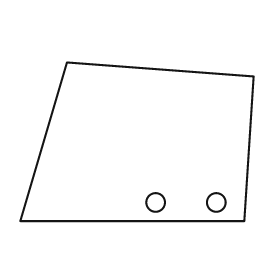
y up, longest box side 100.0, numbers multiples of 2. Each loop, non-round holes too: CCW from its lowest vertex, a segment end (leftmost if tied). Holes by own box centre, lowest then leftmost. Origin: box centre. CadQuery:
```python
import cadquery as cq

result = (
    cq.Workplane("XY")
    .moveTo(-50.0, -34.0)
    .lineTo(46.0, -34.0)
    .lineTo(50.0, 28.0)
    .lineTo(-30.0, 34.0)
    .close()
    .moveTo(8.0, -26.0)
    .circle(4.0)
    .moveTo(34.0, -26.0)
    .circle(4.0)
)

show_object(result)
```